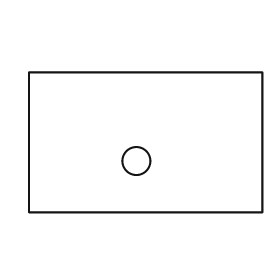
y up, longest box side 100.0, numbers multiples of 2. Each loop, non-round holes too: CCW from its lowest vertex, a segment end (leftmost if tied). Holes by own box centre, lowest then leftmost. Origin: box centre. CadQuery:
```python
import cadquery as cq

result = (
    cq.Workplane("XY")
    .moveTo(-50.0, -30.0)
    .lineTo(50.0, -30.0)
    .lineTo(50.0, 30.0)
    .lineTo(-50.0, 30.0)
    .close()
    .moveTo(-4.0, -8.0)
    .circle(6.0)
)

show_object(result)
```